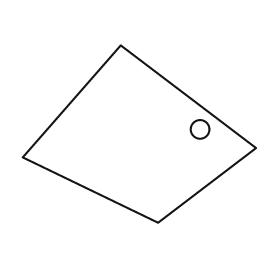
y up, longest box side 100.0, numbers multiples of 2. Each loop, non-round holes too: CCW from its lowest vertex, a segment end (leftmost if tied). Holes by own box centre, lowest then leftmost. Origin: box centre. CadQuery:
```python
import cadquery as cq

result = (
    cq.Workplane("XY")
    .moveTo(8.0, -38.0)
    .lineTo(50.0, -6.0)
    .lineTo(-8.0, 38.0)
    .lineTo(-50.0, -10.0)
    .close()
    .moveTo(26.0, 2.0)
    .circle(4.0)
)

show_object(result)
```